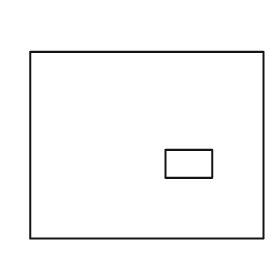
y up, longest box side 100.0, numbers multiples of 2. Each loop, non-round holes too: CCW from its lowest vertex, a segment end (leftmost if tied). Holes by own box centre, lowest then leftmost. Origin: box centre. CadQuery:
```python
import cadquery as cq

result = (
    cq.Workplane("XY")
    .moveTo(-50.0, -40.0)
    .lineTo(50.0, -40.0)
    .lineTo(50.0, 40.0)
    .lineTo(-50.0, 40.0)
    .close()
    .moveTo(8.0, -14.0)
    .lineTo(28.0, -14.0)
    .lineTo(28.0, -2.0)
    .lineTo(8.0, -2.0)
    .close()
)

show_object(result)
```